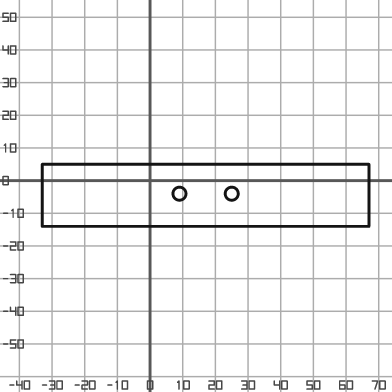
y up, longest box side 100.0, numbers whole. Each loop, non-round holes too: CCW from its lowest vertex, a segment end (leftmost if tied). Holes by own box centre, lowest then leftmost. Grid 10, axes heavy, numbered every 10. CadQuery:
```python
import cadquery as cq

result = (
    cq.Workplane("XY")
    .moveTo(-33.0, -14.0)
    .lineTo(67.0, -14.0)
    .lineTo(67.0, 5.0)
    .lineTo(-33.0, 5.0)
    .close()
    .moveTo(9.0, -4.0)
    .circle(2.0)
    .moveTo(25.0, -4.0)
    .circle(2.0)
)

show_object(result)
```